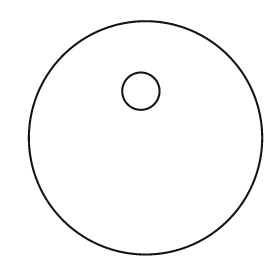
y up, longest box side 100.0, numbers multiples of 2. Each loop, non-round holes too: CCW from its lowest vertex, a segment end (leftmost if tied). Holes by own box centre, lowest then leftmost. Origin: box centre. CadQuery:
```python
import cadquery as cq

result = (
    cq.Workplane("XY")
    .moveTo(0.0, 0.0)
    .circle(50.0)
    .moveTo(-2.0, 20.0)
    .circle(8.0)
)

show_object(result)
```